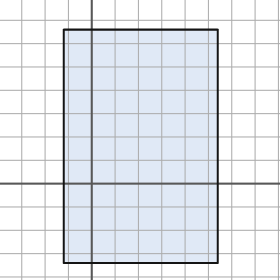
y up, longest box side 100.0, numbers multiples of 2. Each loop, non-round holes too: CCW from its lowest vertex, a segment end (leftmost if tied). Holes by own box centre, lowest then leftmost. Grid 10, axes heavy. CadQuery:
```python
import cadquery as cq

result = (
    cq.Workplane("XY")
    .moveTo(-12.0, -34.0)
    .lineTo(54.0, -34.0)
    .lineTo(54.0, 66.0)
    .lineTo(-12.0, 66.0)
    .close()
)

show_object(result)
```